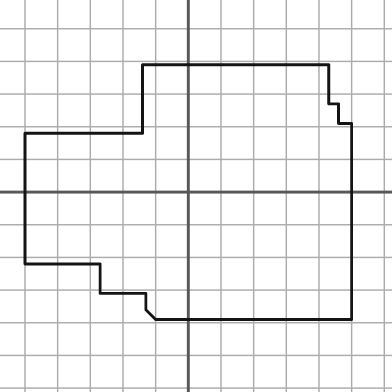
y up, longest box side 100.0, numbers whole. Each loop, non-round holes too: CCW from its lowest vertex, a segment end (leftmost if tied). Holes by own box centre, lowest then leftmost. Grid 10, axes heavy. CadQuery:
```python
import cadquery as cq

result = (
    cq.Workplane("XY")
    .moveTo(-10.0, -39.0)
    .lineTo(50.0, -39.0)
    .lineTo(50.0, 21.0)
    .lineTo(46.0, 21.0)
    .lineTo(46.0, 27.0)
    .lineTo(43.0, 27.0)
    .lineTo(43.0, 39.0)
    .lineTo(-14.0, 39.0)
    .lineTo(-14.0, 18.0)
    .lineTo(-50.0, 18.0)
    .lineTo(-50.0, -22.0)
    .lineTo(-27.0, -22.0)
    .lineTo(-27.0, -31.0)
    .lineTo(-13.0, -31.0)
    .lineTo(-13.0, -36.0)
    .close()
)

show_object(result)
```